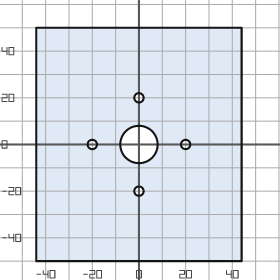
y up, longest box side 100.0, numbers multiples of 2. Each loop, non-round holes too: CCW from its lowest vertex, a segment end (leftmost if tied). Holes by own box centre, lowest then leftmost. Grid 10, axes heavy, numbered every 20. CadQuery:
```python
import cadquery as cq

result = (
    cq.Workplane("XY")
    .moveTo(-44.0, -50.0)
    .lineTo(44.0, -50.0)
    .lineTo(44.0, 50.0)
    .lineTo(-44.0, 50.0)
    .close()
    .moveTo(0.0, -20.0)
    .circle(2.0)
    .moveTo(-20.0, 0.0)
    .circle(2.0)
    .moveTo(0.0, 0.0)
    .circle(8.0)
    .moveTo(20.0, 0.0)
    .circle(2.0)
    .moveTo(0.0, 20.0)
    .circle(2.0)
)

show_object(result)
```